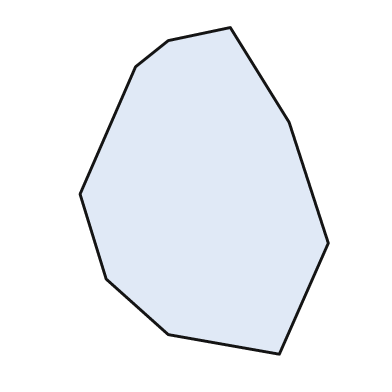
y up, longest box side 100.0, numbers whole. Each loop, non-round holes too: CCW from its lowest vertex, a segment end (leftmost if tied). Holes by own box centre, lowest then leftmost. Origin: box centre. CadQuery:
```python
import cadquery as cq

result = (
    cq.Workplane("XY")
    .moveTo(23.0, -50.0)
    .lineTo(38.0, -16.0)
    .lineTo(26.0, 21.0)
    .lineTo(8.0, 50.0)
    .lineTo(-11.0, 46.0)
    .lineTo(-21.0, 38.0)
    .lineTo(-38.0, -1.0)
    .lineTo(-30.0, -27.0)
    .lineTo(-11.0, -44.0)
    .close()
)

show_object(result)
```